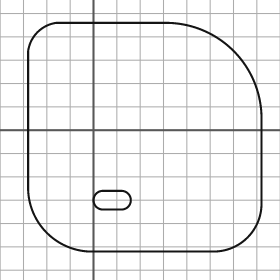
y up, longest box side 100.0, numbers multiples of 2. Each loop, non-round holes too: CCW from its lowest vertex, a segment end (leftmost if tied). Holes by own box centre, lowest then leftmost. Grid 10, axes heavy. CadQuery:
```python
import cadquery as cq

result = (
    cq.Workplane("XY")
    .moveTo(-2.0, -52.0)
    .lineTo(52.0, -52.0)
    .threePointArc((66.0, -46.0), (72.0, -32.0))
    .lineTo(72.0, 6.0)
    .threePointArc((60.0, 34.0), (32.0, 46.0))
    .lineTo(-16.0, 46.0)
    .threePointArc((-24.0, 42.0), (-28.0, 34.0))
    .lineTo(-28.0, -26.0)
    .threePointArc((-20.0, -44.0), (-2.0, -52.0))
    .close()
    .moveTo(4.0, -34.0)
    .lineTo(12.0, -34.0)
    .threePointArc((16.0, -30.0), (12.0, -26.0))
    .lineTo(4.0, -26.0)
    .threePointArc((0.0, -30.0), (4.0, -34.0))
    .close()
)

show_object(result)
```